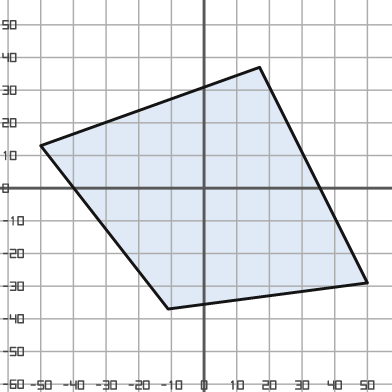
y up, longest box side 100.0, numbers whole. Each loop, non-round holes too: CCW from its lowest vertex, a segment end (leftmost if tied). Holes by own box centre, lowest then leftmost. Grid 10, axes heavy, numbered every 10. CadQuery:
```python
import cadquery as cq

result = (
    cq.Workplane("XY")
    .moveTo(-11.0, -37.0)
    .lineTo(50.0, -29.0)
    .lineTo(17.0, 37.0)
    .lineTo(-50.0, 13.0)
    .close()
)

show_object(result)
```